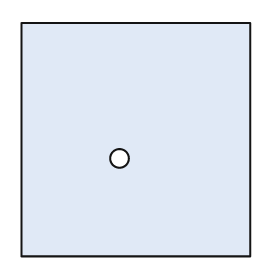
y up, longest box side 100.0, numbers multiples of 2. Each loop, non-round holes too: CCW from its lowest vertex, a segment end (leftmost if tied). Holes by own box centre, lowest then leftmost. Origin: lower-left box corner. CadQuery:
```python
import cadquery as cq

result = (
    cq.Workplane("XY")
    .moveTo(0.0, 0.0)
    .lineTo(98.0, 0.0)
    .lineTo(98.0, 100.0)
    .lineTo(0.0, 100.0)
    .close()
    .moveTo(42.0, 42.0)
    .circle(4.0)
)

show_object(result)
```